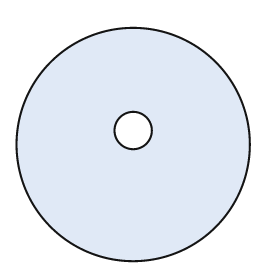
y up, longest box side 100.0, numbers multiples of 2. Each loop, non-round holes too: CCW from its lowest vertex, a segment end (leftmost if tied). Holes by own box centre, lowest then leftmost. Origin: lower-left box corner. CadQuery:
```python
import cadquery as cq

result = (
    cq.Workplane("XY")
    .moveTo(50.0, 50.0)
    .circle(50.0)
    .moveTo(50.0, 56.0)
    .circle(8.0)
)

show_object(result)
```